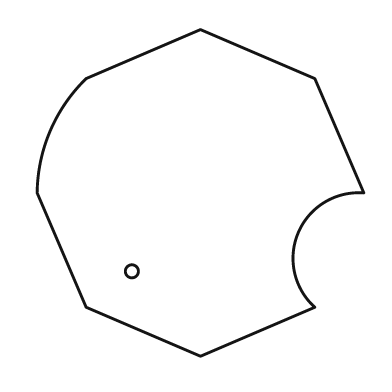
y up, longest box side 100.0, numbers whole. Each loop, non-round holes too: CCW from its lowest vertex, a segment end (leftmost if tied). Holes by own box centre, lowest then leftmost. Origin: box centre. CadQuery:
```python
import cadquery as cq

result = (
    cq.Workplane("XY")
    .moveTo(0.0, -50.0)
    .lineTo(35.0, -35.0)
    .threePointArc((30.0, -12.0), (50.0, 0.0))
    .lineTo(35.0, 35.0)
    .lineTo(0.0, 50.0)
    .lineTo(-35.0, 35.0)
    .threePointArc((-46.0, 19.0), (-50.0, 0.0))
    .lineTo(-35.0, -35.0)
    .close()
    .moveTo(-21.0, -24.0)
    .circle(2.0)
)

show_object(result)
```